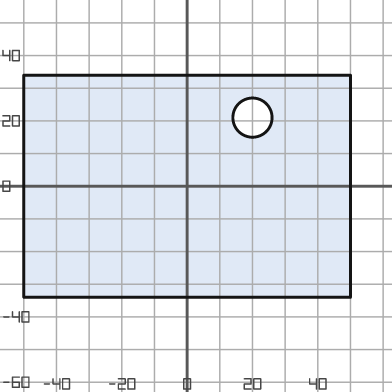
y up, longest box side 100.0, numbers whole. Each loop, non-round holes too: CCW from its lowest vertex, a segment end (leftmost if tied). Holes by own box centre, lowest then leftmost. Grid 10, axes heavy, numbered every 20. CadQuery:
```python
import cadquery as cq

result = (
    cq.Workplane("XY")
    .moveTo(-50.0, -34.0)
    .lineTo(50.0, -34.0)
    .lineTo(50.0, 34.0)
    .lineTo(-50.0, 34.0)
    .close()
    .moveTo(20.0, 21.0)
    .circle(6.0)
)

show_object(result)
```